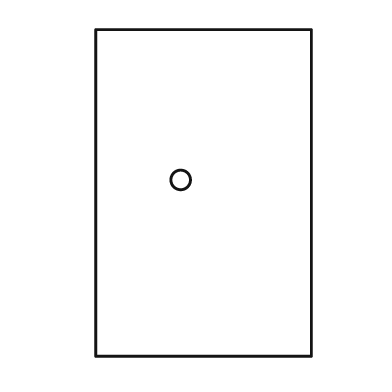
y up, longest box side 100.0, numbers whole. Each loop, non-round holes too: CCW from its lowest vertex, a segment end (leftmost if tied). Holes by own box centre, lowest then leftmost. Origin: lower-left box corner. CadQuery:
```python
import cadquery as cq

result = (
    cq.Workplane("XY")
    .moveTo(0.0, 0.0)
    .lineTo(66.0, 0.0)
    .lineTo(66.0, 100.0)
    .lineTo(0.0, 100.0)
    .close()
    .moveTo(26.0, 54.0)
    .circle(3.0)
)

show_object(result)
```